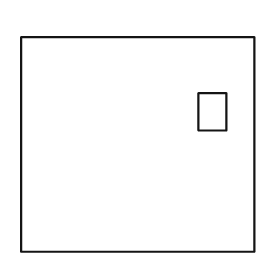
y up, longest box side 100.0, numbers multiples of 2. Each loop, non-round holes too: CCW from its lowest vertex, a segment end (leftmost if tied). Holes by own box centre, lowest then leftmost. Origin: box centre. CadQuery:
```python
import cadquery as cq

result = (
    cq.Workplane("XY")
    .moveTo(-50.0, -46.0)
    .lineTo(50.0, -46.0)
    .lineTo(50.0, 46.0)
    .lineTo(-50.0, 46.0)
    .close()
    .moveTo(26.0, 6.0)
    .lineTo(38.0, 6.0)
    .lineTo(38.0, 22.0)
    .lineTo(26.0, 22.0)
    .close()
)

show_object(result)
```